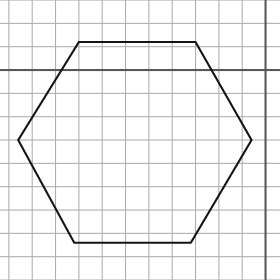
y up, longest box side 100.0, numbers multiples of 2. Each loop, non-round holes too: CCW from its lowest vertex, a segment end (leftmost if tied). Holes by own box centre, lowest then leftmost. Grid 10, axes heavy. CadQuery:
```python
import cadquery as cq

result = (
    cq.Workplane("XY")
    .moveTo(-82.0, -74.0)
    .lineTo(-32.0, -74.0)
    .lineTo(-6.0, -30.0)
    .lineTo(-30.0, 12.0)
    .lineTo(-80.0, 12.0)
    .lineTo(-106.0, -30.0)
    .close()
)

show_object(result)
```